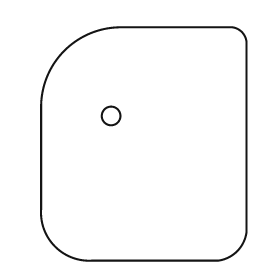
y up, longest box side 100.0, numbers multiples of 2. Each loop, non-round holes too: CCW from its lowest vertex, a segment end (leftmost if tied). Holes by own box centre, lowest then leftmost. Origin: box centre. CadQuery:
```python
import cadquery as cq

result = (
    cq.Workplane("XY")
    .moveTo(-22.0, -50.0)
    .lineTo(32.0, -50.0)
    .threePointArc((40.0, -46.0), (44.0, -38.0))
    .lineTo(44.0, 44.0)
    .threePointArc((42.0, 48.0), (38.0, 50.0))
    .lineTo(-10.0, 50.0)
    .threePointArc((-34.0, 40.0), (-44.0, 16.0))
    .lineTo(-44.0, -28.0)
    .threePointArc((-38.0, -44.0), (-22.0, -50.0))
    .close()
    .moveTo(-14.0, 12.0)
    .circle(4.0)
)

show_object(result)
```